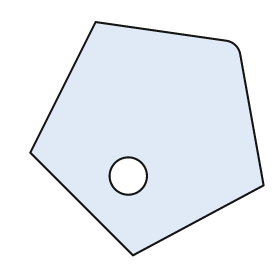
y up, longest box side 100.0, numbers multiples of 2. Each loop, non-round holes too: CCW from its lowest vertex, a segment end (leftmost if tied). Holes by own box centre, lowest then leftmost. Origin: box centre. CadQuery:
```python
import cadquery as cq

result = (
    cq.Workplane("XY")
    .moveTo(-6.0, -50.0)
    .lineTo(50.0, -20.0)
    .lineTo(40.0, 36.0)
    .threePointArc((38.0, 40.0), (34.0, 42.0))
    .lineTo(-22.0, 50.0)
    .lineTo(-50.0, -6.0)
    .close()
    .moveTo(-8.0, -16.0)
    .circle(8.0)
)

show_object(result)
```